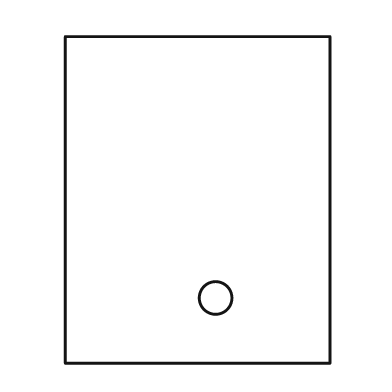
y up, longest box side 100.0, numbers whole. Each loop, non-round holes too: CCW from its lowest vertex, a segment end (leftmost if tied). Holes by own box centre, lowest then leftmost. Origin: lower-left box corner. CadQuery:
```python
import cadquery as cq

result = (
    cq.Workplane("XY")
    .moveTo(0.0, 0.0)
    .lineTo(81.0, 0.0)
    .lineTo(81.0, 100.0)
    .lineTo(0.0, 100.0)
    .close()
    .moveTo(46.0, 20.0)
    .circle(5.0)
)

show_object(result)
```